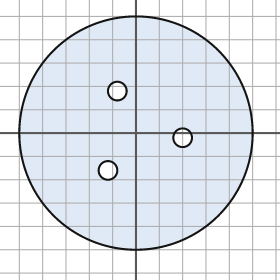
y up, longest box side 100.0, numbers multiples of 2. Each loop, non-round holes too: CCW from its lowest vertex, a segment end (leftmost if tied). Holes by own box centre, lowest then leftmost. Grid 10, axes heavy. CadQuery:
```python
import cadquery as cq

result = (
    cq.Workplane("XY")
    .moveTo(0.0, 0.0)
    .circle(50.0)
    .moveTo(-12.0, -16.0)
    .circle(4.0)
    .moveTo(20.0, -2.0)
    .circle(4.0)
    .moveTo(-8.0, 18.0)
    .circle(4.0)
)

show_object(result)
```